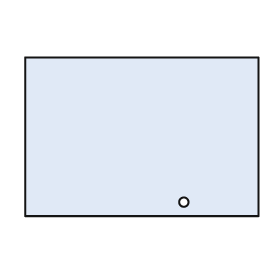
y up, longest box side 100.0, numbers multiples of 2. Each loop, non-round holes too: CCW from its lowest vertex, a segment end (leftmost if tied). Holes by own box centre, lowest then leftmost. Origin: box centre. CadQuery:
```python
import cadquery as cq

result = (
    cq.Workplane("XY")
    .moveTo(-50.0, -34.0)
    .lineTo(50.0, -34.0)
    .lineTo(50.0, 34.0)
    .lineTo(-50.0, 34.0)
    .close()
    .moveTo(18.0, -28.0)
    .circle(2.0)
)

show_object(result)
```